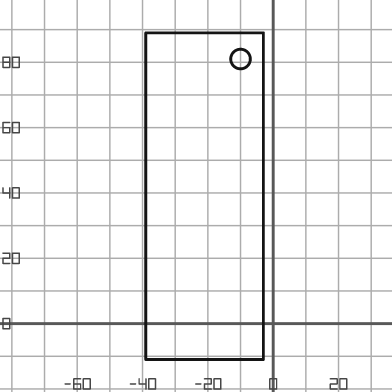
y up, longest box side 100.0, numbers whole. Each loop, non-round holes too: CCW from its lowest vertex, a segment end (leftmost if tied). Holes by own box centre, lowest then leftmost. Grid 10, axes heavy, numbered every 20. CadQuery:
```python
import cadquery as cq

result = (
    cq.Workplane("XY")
    .moveTo(-39.0, -11.0)
    .lineTo(-3.0, -11.0)
    .lineTo(-3.0, 89.0)
    .lineTo(-39.0, 89.0)
    .close()
    .moveTo(-10.0, 81.0)
    .circle(3.0)
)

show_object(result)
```